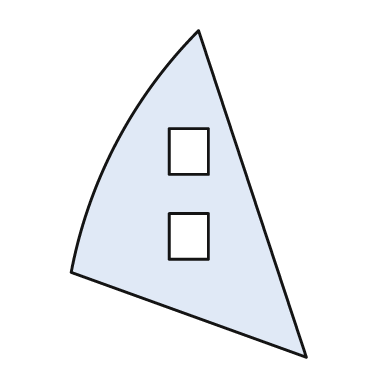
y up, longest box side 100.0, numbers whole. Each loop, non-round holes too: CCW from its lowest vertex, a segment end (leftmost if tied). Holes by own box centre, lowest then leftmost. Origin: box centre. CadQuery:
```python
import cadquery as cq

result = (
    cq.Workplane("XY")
    .moveTo(36.0, -50.0)
    .lineTo(3.0, 50.0)
    .threePointArc((-22.0, 16.0), (-36.0, -24.0))
    .close()
    .moveTo(-6.0, -20.0)
    .lineTo(6.0, -20.0)
    .lineTo(6.0, -6.0)
    .lineTo(-6.0, -6.0)
    .close()
    .moveTo(-6.0, 6.0)
    .lineTo(6.0, 6.0)
    .lineTo(6.0, 20.0)
    .lineTo(-6.0, 20.0)
    .close()
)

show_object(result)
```